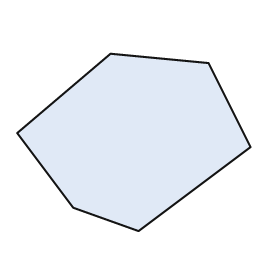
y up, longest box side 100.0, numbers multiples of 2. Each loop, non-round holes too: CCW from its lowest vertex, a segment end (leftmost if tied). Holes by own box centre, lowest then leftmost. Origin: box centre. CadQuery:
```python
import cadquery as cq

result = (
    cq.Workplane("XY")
    .moveTo(2.0, -38.0)
    .lineTo(50.0, -2.0)
    .lineTo(32.0, 34.0)
    .lineTo(-10.0, 38.0)
    .lineTo(-50.0, 4.0)
    .lineTo(-26.0, -28.0)
    .close()
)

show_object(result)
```